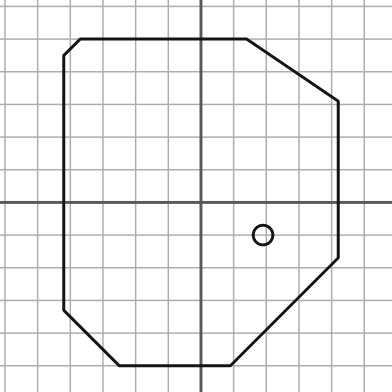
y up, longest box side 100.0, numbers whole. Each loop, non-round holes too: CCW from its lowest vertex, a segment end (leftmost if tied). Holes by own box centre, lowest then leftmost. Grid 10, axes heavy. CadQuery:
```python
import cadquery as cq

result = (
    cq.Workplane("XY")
    .moveTo(-25.0, -50.0)
    .lineTo(9.0, -50.0)
    .lineTo(42.0, -17.0)
    .lineTo(42.0, 31.0)
    .lineTo(14.0, 50.0)
    .lineTo(-37.0, 50.0)
    .lineTo(-42.0, 45.0)
    .lineTo(-42.0, -33.0)
    .close()
    .moveTo(19.0, -10.0)
    .circle(3.0)
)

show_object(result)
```